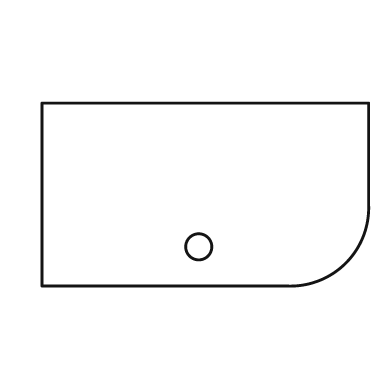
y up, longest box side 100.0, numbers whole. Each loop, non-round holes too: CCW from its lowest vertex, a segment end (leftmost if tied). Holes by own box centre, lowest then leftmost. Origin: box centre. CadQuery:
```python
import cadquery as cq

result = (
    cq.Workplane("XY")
    .moveTo(-50.0, -28.0)
    .lineTo(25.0, -28.0)
    .threePointArc((43.0, -21.0), (50.0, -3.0))
    .lineTo(50.0, 28.0)
    .lineTo(-50.0, 28.0)
    .close()
    .moveTo(-2.0, -16.0)
    .circle(4.0)
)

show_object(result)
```